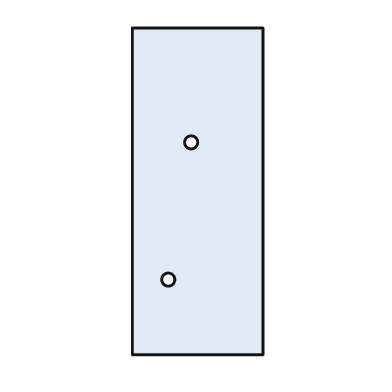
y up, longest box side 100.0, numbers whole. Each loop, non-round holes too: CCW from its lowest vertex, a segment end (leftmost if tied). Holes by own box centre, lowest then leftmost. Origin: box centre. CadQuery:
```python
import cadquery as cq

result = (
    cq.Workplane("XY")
    .moveTo(-20.0, -50.0)
    .lineTo(20.0, -50.0)
    .lineTo(20.0, 50.0)
    .lineTo(-20.0, 50.0)
    .close()
    .moveTo(-9.0, -27.0)
    .circle(2.0)
    .moveTo(-2.0, 15.0)
    .circle(2.0)
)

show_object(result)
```